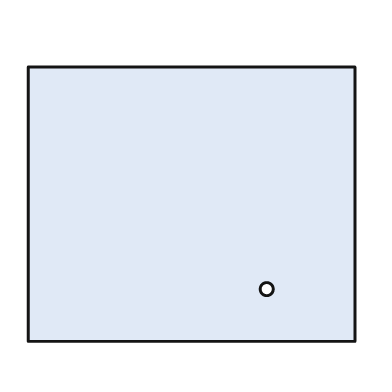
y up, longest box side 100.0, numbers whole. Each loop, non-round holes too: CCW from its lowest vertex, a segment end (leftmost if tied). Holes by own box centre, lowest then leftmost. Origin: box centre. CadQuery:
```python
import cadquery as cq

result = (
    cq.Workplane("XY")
    .moveTo(-50.0, -42.0)
    .lineTo(50.0, -42.0)
    .lineTo(50.0, 42.0)
    .lineTo(-50.0, 42.0)
    .close()
    .moveTo(23.0, -26.0)
    .circle(2.0)
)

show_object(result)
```